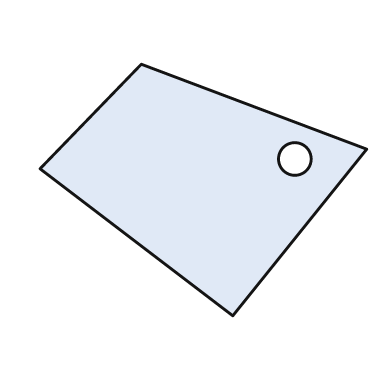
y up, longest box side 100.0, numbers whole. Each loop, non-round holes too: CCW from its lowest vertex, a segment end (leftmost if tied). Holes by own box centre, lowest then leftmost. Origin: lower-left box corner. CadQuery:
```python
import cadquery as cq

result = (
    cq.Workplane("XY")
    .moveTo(59.0, 0.0)
    .lineTo(100.0, 51.0)
    .lineTo(31.0, 77.0)
    .lineTo(0.0, 45.0)
    .close()
    .moveTo(78.0, 48.0)
    .circle(5.0)
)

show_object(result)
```